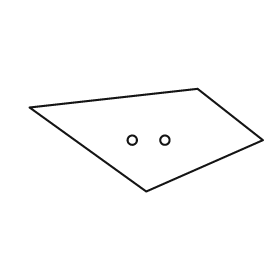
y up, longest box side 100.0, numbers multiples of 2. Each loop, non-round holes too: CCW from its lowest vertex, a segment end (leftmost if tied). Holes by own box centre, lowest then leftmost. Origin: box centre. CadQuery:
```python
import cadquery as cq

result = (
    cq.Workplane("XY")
    .moveTo(0.0, -22.0)
    .lineTo(50.0, 0.0)
    .lineTo(22.0, 22.0)
    .lineTo(-50.0, 14.0)
    .close()
    .moveTo(-6.0, 0.0)
    .circle(2.0)
    .moveTo(8.0, 0.0)
    .circle(2.0)
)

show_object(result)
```